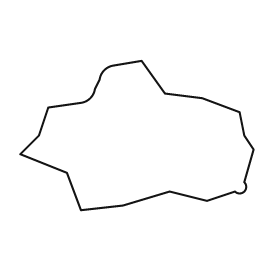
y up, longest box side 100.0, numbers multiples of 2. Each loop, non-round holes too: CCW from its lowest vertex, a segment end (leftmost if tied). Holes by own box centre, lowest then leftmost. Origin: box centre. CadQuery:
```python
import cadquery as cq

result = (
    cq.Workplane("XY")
    .moveTo(-24.0, -32.0)
    .lineTo(-6.0, -30.0)
    .lineTo(14.0, -24.0)
    .lineTo(30.0, -28.0)
    .lineTo(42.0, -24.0)
    .threePointArc((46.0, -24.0), (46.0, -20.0))
    .lineTo(50.0, -6.0)
    .lineTo(46.0, 0.0)
    .lineTo(44.0, 10.0)
    .lineTo(28.0, 16.0)
    .lineTo(12.0, 18.0)
    .lineTo(2.0, 32.0)
    .lineTo(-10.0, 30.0)
    .threePointArc((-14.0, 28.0), (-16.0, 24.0))
    .lineTo(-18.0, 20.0)
    .threePointArc((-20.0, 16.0), (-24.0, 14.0))
    .lineTo(-38.0, 12.0)
    .lineTo(-42.0, 0.0)
    .lineTo(-50.0, -8.0)
    .lineTo(-30.0, -16.0)
    .close()
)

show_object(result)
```